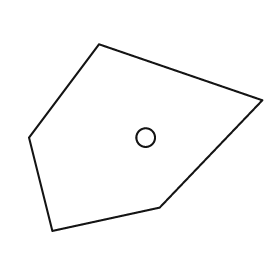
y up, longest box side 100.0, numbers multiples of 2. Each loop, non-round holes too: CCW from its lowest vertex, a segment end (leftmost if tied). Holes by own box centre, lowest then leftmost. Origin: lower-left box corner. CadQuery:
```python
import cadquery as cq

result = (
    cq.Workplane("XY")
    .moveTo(10.0, 0.0)
    .lineTo(56.0, 10.0)
    .lineTo(100.0, 56.0)
    .lineTo(30.0, 80.0)
    .lineTo(0.0, 40.0)
    .close()
    .moveTo(50.0, 40.0)
    .circle(4.0)
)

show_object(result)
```